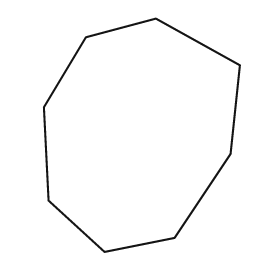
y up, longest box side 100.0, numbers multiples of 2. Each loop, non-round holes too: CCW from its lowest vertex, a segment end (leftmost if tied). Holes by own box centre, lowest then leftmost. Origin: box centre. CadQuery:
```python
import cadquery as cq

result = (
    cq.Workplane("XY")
    .moveTo(-16.0, -50.0)
    .lineTo(14.0, -44.0)
    .lineTo(38.0, -8.0)
    .lineTo(42.0, 30.0)
    .lineTo(6.0, 50.0)
    .lineTo(-24.0, 42.0)
    .lineTo(-42.0, 12.0)
    .lineTo(-40.0, -28.0)
    .close()
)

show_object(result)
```